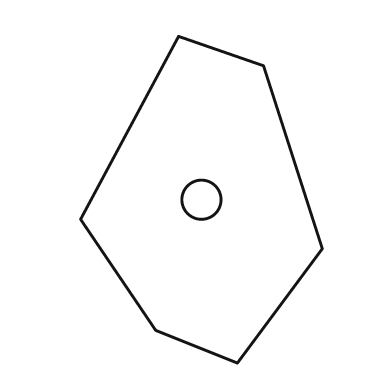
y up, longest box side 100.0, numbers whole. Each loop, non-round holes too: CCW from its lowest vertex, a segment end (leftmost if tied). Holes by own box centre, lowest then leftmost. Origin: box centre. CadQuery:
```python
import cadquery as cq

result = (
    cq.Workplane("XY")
    .moveTo(11.0, -50.0)
    .lineTo(37.0, -15.0)
    .lineTo(19.0, 41.0)
    .lineTo(-7.0, 50.0)
    .lineTo(-37.0, -6.0)
    .lineTo(-14.0, -40.0)
    .close()
    .moveTo(0.0, 0.0)
    .circle(6.0)
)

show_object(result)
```